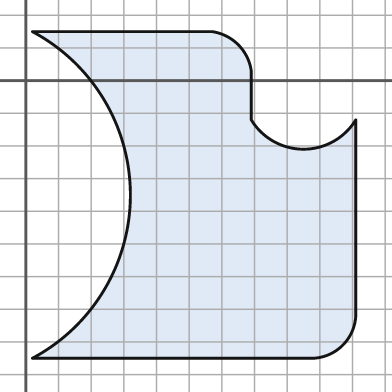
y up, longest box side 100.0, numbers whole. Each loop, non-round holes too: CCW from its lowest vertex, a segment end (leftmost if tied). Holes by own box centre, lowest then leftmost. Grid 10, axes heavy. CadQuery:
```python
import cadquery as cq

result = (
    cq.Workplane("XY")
    .moveTo(2.0, -85.0)
    .lineTo(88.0, -85.0)
    .threePointArc((97.0, -81.0), (101.0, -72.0))
    .lineTo(101.0, -12.0)
    .threePointArc((85.0, -21.0), (69.0, -12.0))
    .lineTo(69.0, 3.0)
    .threePointArc((65.0, 11.0), (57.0, 15.0))
    .lineTo(2.0, 15.0)
    .threePointArc((32.0, -35.0), (2.0, -85.0))
    .close()
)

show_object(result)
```